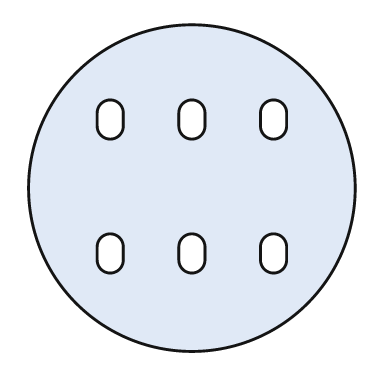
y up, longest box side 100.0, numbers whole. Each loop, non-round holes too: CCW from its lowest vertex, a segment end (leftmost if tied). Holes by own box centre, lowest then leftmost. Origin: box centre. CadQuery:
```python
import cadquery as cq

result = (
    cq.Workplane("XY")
    .moveTo(0.0, 0.0)
    .circle(50.0)
    .moveTo(-29.0, -22.0)
    .threePointArc((-25.0, -26.0), (-21.0, -22.0))
    .lineTo(-21.0, -18.0)
    .threePointArc((-25.0, -14.0), (-29.0, -18.0))
    .close()
    .moveTo(-4.0, -22.0)
    .threePointArc((0.0, -26.0), (4.0, -22.0))
    .lineTo(4.0, -18.0)
    .threePointArc((0.0, -14.0), (-4.0, -18.0))
    .close()
    .moveTo(21.0, -22.0)
    .threePointArc((25.0, -26.0), (29.0, -22.0))
    .lineTo(29.0, -18.0)
    .threePointArc((25.0, -14.0), (21.0, -18.0))
    .close()
    .moveTo(-29.0, 19.0)
    .threePointArc((-25.0, 15.0), (-21.0, 19.0))
    .lineTo(-21.0, 23.0)
    .threePointArc((-25.0, 27.0), (-29.0, 23.0))
    .close()
    .moveTo(-4.0, 19.0)
    .threePointArc((0.0, 15.0), (4.0, 19.0))
    .lineTo(4.0, 23.0)
    .threePointArc((0.0, 27.0), (-4.0, 23.0))
    .close()
    .moveTo(21.0, 19.0)
    .threePointArc((25.0, 15.0), (29.0, 19.0))
    .lineTo(29.0, 23.0)
    .threePointArc((25.0, 27.0), (21.0, 23.0))
    .close()
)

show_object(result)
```